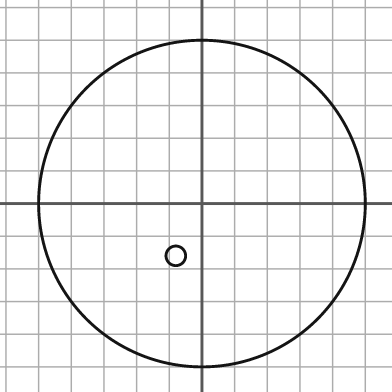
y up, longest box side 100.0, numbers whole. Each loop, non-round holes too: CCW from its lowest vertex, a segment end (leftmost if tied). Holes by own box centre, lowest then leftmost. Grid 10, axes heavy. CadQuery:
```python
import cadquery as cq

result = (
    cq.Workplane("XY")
    .moveTo(0.0, 0.0)
    .circle(50.0)
    .moveTo(-8.0, -16.0)
    .circle(3.0)
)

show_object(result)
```